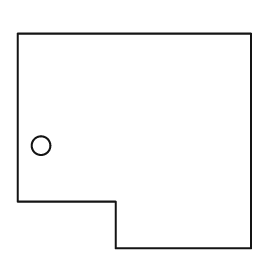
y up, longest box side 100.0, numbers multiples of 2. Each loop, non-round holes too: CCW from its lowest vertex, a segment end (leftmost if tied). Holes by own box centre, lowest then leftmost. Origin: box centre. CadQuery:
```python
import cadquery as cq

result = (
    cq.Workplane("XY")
    .moveTo(-8.0, -46.0)
    .lineTo(50.0, -46.0)
    .lineTo(50.0, 46.0)
    .lineTo(-50.0, 46.0)
    .lineTo(-50.0, -26.0)
    .lineTo(-8.0, -26.0)
    .close()
    .moveTo(-40.0, -2.0)
    .circle(4.0)
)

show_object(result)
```